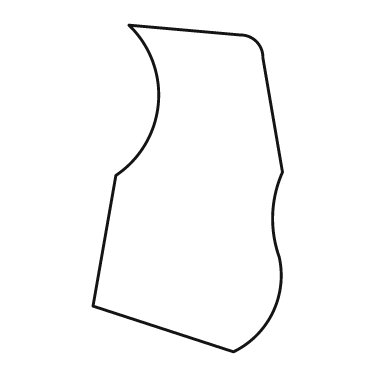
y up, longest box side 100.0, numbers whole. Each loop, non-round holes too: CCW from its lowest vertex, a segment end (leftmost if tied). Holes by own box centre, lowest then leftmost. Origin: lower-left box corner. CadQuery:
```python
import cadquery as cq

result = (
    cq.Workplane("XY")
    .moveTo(43.0, 0.0)
    .threePointArc((55.0, 12.0), (57.0, 29.0))
    .threePointArc((55.0, 42.0), (58.0, 55.0))
    .lineTo(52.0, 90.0)
    .threePointArc((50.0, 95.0), (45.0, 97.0))
    .lineTo(11.0, 100.0)
    .threePointArc((20.0, 76.0), (7.0, 54.0))
    .lineTo(0.0, 14.0)
    .close()
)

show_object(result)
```